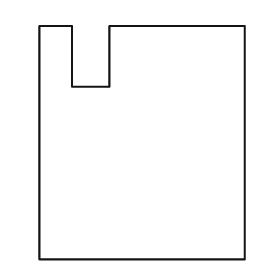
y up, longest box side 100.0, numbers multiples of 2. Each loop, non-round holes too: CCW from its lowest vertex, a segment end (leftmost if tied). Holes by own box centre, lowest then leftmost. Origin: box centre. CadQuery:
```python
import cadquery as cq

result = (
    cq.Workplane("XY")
    .moveTo(-44.0, -50.0)
    .lineTo(44.0, -50.0)
    .lineTo(44.0, 50.0)
    .lineTo(-14.0, 50.0)
    .lineTo(-14.0, 24.0)
    .lineTo(-30.0, 24.0)
    .lineTo(-30.0, 50.0)
    .lineTo(-44.0, 50.0)
    .close()
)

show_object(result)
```